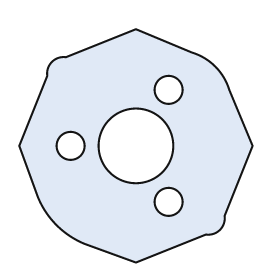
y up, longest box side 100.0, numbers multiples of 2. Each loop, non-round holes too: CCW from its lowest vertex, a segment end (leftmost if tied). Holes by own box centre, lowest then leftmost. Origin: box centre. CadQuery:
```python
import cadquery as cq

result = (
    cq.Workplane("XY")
    .moveTo(0.0, -50.0)
    .lineTo(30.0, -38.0)
    .threePointArc((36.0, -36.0), (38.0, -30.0))
    .lineTo(50.0, 0.0)
    .lineTo(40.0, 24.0)
    .threePointArc((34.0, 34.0), (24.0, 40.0))
    .lineTo(0.0, 50.0)
    .lineTo(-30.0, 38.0)
    .threePointArc((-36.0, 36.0), (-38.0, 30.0))
    .lineTo(-50.0, 0.0)
    .lineTo(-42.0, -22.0)
    .threePointArc((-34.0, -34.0), (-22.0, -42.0))
    .close()
    .moveTo(14.0, -24.0)
    .circle(6.0)
    .moveTo(-28.0, 0.0)
    .circle(6.0)
    .moveTo(0.0, 0.0)
    .circle(16.0)
    .moveTo(14.0, 24.0)
    .circle(6.0)
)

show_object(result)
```